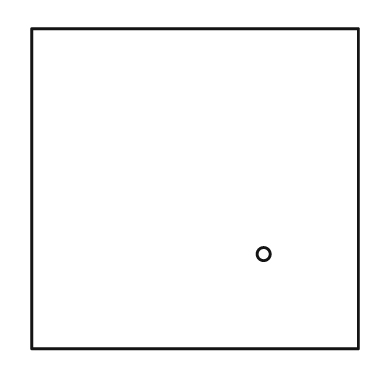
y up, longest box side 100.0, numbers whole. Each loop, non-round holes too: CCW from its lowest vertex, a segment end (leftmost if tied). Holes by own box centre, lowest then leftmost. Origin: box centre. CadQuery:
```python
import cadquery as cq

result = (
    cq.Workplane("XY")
    .moveTo(-50.0, -49.0)
    .lineTo(50.0, -49.0)
    .lineTo(50.0, 49.0)
    .lineTo(-50.0, 49.0)
    .close()
    .moveTo(21.0, -20.0)
    .circle(2.0)
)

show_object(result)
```